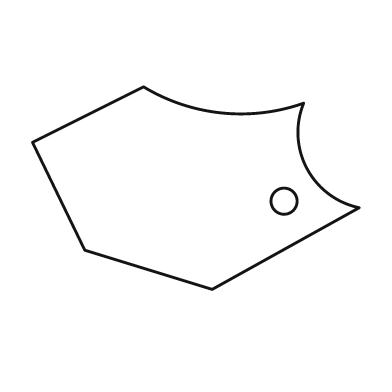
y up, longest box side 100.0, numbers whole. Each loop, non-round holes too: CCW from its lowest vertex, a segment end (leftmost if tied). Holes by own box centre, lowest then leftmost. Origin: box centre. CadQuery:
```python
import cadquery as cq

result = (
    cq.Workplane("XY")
    .moveTo(5.0, -31.0)
    .lineTo(50.0, -6.0)
    .threePointArc((34.0, 6.0), (33.0, 26.0))
    .threePointArc((8.0, 23.0), (-16.0, 31.0))
    .lineTo(-50.0, 14.0)
    .lineTo(-34.0, -19.0)
    .close()
    .moveTo(27.0, -4.0)
    .circle(4.0)
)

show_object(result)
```